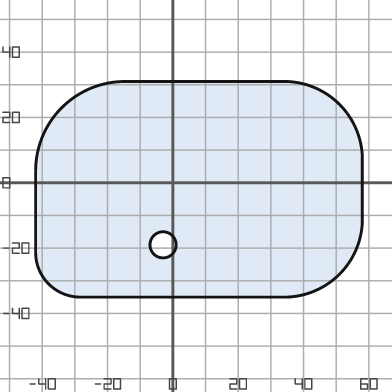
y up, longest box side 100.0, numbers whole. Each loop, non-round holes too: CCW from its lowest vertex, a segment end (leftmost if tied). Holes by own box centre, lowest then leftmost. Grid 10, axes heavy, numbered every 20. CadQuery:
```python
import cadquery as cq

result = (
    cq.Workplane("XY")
    .moveTo(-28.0, -35.0)
    .lineTo(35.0, -35.0)
    .threePointArc((51.0, -28.0), (58.0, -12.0))
    .lineTo(58.0, 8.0)
    .threePointArc((51.0, 24.0), (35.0, 31.0))
    .lineTo(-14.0, 31.0)
    .threePointArc((-34.0, 23.0), (-42.0, 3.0))
    .lineTo(-42.0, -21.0)
    .threePointArc((-38.0, -31.0), (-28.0, -35.0))
    .close()
    .moveTo(-3.0, -19.0)
    .circle(4.0)
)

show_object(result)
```